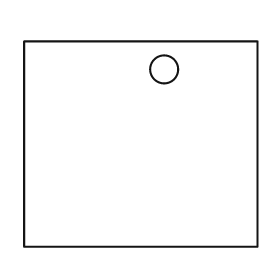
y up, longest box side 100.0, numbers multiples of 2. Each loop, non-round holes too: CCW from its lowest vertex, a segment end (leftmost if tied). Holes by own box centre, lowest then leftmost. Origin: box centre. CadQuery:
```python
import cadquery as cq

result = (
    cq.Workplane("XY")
    .moveTo(-50.0, -44.0)
    .lineTo(50.0, -44.0)
    .lineTo(50.0, 44.0)
    .lineTo(-50.0, 44.0)
    .close()
    .moveTo(10.0, 32.0)
    .circle(6.0)
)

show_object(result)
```